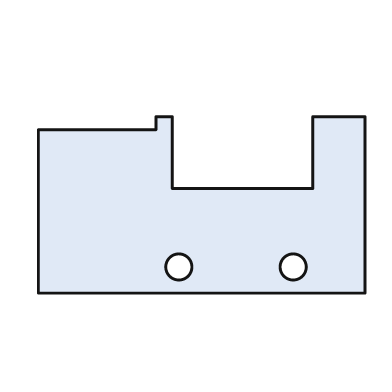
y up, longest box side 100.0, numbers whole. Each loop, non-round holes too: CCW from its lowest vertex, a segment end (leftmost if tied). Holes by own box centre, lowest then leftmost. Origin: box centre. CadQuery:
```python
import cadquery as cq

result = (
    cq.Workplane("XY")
    .moveTo(-50.0, -27.0)
    .lineTo(50.0, -27.0)
    .lineTo(50.0, 27.0)
    .lineTo(34.0, 27.0)
    .lineTo(34.0, 5.0)
    .lineTo(-9.0, 5.0)
    .lineTo(-9.0, 27.0)
    .lineTo(-14.0, 27.0)
    .lineTo(-14.0, 23.0)
    .lineTo(-50.0, 23.0)
    .close()
    .moveTo(-7.0, -19.0)
    .circle(4.0)
    .moveTo(28.0, -19.0)
    .circle(4.0)
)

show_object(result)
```